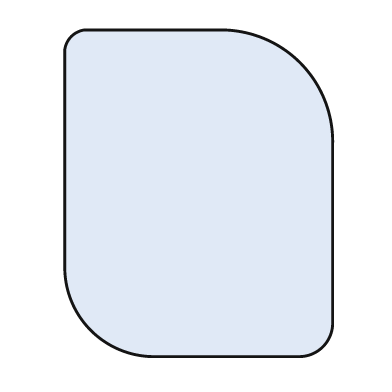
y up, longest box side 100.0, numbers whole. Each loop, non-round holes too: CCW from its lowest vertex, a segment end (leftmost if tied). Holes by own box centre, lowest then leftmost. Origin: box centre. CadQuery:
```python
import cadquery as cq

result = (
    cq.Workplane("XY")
    .moveTo(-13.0, -50.0)
    .lineTo(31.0, -50.0)
    .threePointArc((38.0, -47.0), (41.0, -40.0))
    .lineTo(41.0, 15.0)
    .threePointArc((31.0, 40.0), (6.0, 50.0))
    .lineTo(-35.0, 50.0)
    .threePointArc((-39.0, 48.0), (-41.0, 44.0))
    .lineTo(-41.0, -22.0)
    .threePointArc((-33.0, -42.0), (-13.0, -50.0))
    .close()
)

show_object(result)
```